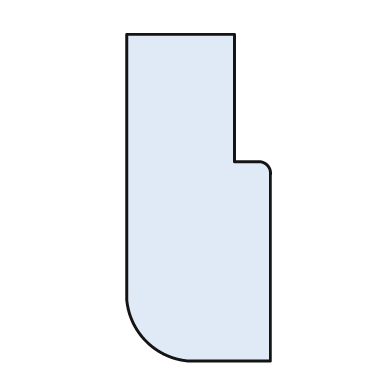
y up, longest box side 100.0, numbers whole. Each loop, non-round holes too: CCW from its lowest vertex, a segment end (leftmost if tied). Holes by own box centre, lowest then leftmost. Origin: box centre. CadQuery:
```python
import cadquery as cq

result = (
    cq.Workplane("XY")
    .moveTo(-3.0, -50.0)
    .lineTo(22.0, -50.0)
    .lineTo(22.0, 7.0)
    .threePointArc((21.0, 10.0), (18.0, 11.0))
    .lineTo(11.0, 11.0)
    .lineTo(11.0, 50.0)
    .lineTo(-22.0, 50.0)
    .lineTo(-22.0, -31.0)
    .threePointArc((-16.0, -44.0), (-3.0, -50.0))
    .close()
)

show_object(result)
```